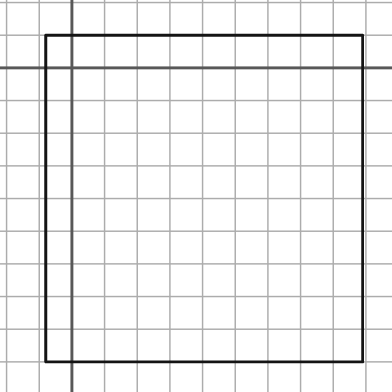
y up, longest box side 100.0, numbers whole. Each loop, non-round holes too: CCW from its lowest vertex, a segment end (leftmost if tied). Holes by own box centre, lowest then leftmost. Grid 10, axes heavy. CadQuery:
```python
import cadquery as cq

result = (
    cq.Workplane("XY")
    .moveTo(-8.0, -90.0)
    .lineTo(89.0, -90.0)
    .lineTo(89.0, 10.0)
    .lineTo(-8.0, 10.0)
    .close()
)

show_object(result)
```